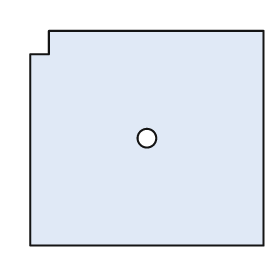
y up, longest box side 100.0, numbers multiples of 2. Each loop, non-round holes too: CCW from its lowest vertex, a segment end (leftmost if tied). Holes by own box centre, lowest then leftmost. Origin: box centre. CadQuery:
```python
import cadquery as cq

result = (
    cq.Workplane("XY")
    .moveTo(-50.0, -46.0)
    .lineTo(50.0, -46.0)
    .lineTo(50.0, 46.0)
    .lineTo(-42.0, 46.0)
    .lineTo(-42.0, 36.0)
    .lineTo(-50.0, 36.0)
    .close()
    .moveTo(0.0, 0.0)
    .circle(4.0)
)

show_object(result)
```